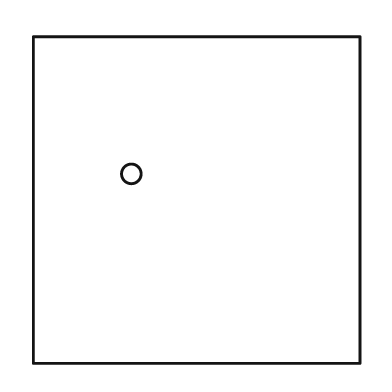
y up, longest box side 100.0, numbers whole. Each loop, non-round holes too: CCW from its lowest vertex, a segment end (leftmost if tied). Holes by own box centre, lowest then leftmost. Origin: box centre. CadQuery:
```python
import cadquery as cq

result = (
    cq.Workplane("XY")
    .moveTo(-50.0, -50.0)
    .lineTo(50.0, -50.0)
    .lineTo(50.0, 50.0)
    .lineTo(-50.0, 50.0)
    .close()
    .moveTo(-20.0, 8.0)
    .circle(3.0)
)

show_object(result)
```